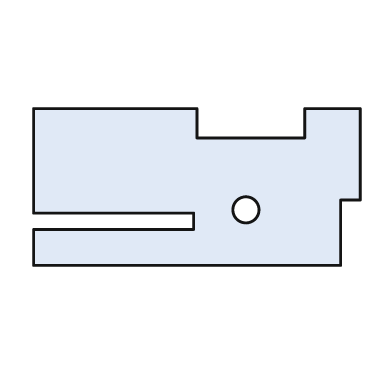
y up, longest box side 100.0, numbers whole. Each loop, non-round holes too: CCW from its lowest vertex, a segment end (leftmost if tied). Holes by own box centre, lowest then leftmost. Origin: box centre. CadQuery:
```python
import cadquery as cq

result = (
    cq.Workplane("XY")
    .moveTo(-50.0, -24.0)
    .lineTo(44.0, -24.0)
    .lineTo(44.0, -4.0)
    .lineTo(50.0, -4.0)
    .lineTo(50.0, 24.0)
    .lineTo(33.0, 24.0)
    .lineTo(33.0, 15.0)
    .lineTo(0.0, 15.0)
    .lineTo(0.0, 24.0)
    .lineTo(-50.0, 24.0)
    .lineTo(-50.0, -8.0)
    .lineTo(-1.0, -8.0)
    .lineTo(-1.0, -13.0)
    .lineTo(-50.0, -13.0)
    .close()
    .moveTo(15.0, -7.0)
    .circle(4.0)
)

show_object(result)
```